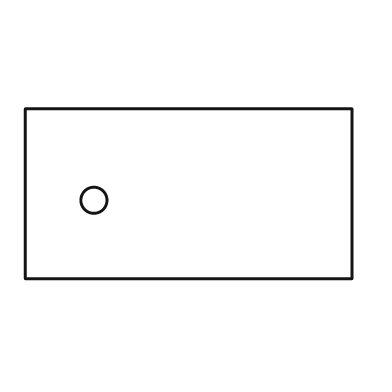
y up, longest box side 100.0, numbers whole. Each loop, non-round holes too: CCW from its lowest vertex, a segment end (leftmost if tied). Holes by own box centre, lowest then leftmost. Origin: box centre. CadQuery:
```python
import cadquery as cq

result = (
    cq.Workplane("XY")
    .moveTo(-50.0, -26.0)
    .lineTo(50.0, -26.0)
    .lineTo(50.0, 26.0)
    .lineTo(-50.0, 26.0)
    .close()
    .moveTo(-29.0, -2.0)
    .circle(4.0)
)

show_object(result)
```